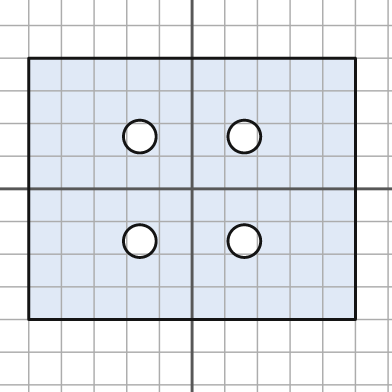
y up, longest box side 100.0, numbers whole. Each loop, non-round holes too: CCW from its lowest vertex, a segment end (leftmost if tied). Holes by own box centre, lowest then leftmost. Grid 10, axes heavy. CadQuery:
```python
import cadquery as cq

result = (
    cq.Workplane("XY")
    .moveTo(-50.0, -40.0)
    .lineTo(50.0, -40.0)
    .lineTo(50.0, 40.0)
    .lineTo(-50.0, 40.0)
    .close()
    .moveTo(-16.0, -16.0)
    .circle(5.0)
    .moveTo(16.0, -16.0)
    .circle(5.0)
    .moveTo(-16.0, 16.0)
    .circle(5.0)
    .moveTo(16.0, 16.0)
    .circle(5.0)
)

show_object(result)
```